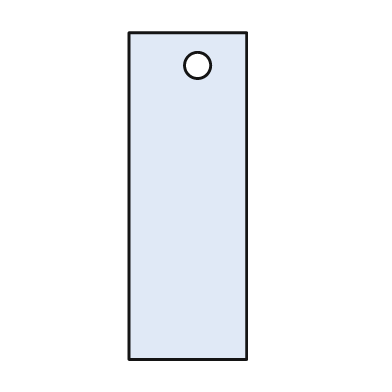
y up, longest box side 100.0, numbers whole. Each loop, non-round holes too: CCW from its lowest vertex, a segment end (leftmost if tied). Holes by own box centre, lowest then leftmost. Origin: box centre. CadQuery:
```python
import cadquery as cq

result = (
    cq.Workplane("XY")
    .moveTo(-18.0, -50.0)
    .lineTo(18.0, -50.0)
    .lineTo(18.0, 50.0)
    .lineTo(-18.0, 50.0)
    .close()
    .moveTo(3.0, 40.0)
    .circle(4.0)
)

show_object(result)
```